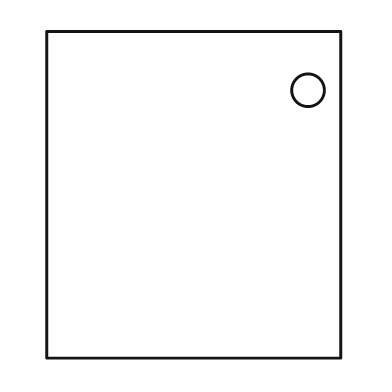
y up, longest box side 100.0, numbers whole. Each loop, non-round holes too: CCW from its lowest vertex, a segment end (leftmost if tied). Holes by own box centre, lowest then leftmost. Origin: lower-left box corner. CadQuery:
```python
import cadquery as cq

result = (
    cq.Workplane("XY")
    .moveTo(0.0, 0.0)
    .lineTo(90.0, 0.0)
    .lineTo(90.0, 100.0)
    .lineTo(0.0, 100.0)
    .close()
    .moveTo(80.0, 82.0)
    .circle(5.0)
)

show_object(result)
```